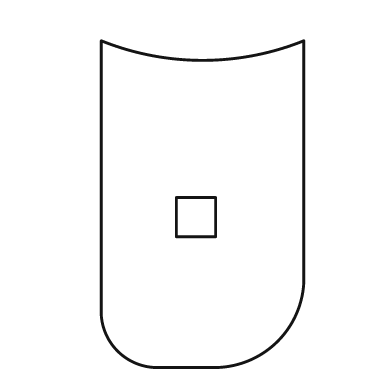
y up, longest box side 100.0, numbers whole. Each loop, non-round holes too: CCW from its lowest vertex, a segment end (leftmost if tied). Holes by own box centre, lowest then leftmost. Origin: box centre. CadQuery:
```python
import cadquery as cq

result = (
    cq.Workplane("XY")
    .moveTo(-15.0, -50.0)
    .lineTo(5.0, -50.0)
    .threePointArc((23.0, -42.0), (31.0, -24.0))
    .lineTo(31.0, 50.0)
    .threePointArc((0.0, 44.0), (-31.0, 50.0))
    .lineTo(-31.0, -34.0)
    .threePointArc((-26.0, -45.0), (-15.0, -50.0))
    .close()
    .moveTo(-8.0, -10.0)
    .lineTo(4.0, -10.0)
    .lineTo(4.0, 2.0)
    .lineTo(-8.0, 2.0)
    .close()
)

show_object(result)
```